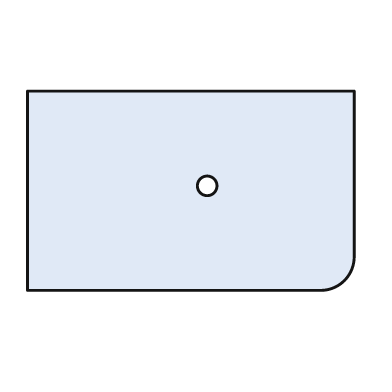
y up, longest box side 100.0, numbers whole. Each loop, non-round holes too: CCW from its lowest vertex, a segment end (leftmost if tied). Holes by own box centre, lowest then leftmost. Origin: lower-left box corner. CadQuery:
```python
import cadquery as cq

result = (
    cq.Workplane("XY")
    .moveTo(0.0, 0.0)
    .lineTo(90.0, 0.0)
    .threePointArc((97.0, 3.0), (100.0, 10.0))
    .lineTo(100.0, 61.0)
    .lineTo(0.0, 61.0)
    .close()
    .moveTo(55.0, 32.0)
    .circle(3.0)
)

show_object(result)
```